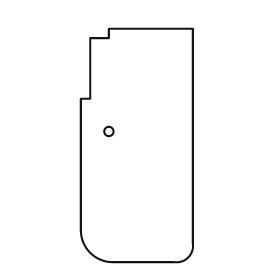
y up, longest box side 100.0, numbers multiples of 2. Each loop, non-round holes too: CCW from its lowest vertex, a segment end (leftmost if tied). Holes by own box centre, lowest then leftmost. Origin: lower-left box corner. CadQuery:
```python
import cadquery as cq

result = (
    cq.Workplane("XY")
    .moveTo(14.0, 0.0)
    .lineTo(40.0, 0.0)
    .threePointArc((46.0, 2.0), (48.0, 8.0))
    .lineTo(48.0, 100.0)
    .lineTo(12.0, 100.0)
    .lineTo(12.0, 96.0)
    .lineTo(4.0, 96.0)
    .lineTo(4.0, 70.0)
    .lineTo(0.0, 70.0)
    .lineTo(0.0, 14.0)
    .threePointArc((4.0, 4.0), (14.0, 0.0))
    .close()
    .moveTo(12.0, 56.0)
    .circle(2.0)
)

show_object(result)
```